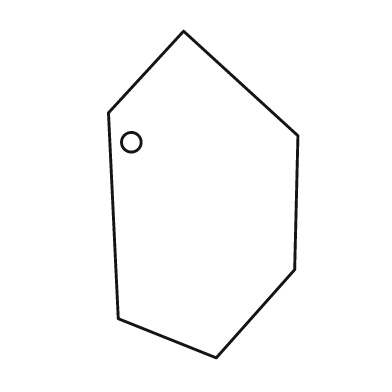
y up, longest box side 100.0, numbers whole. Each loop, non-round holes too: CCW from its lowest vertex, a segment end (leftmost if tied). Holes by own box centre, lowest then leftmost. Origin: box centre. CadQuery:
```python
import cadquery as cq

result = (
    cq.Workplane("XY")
    .moveTo(4.0, -50.0)
    .lineTo(28.0, -23.0)
    .lineTo(29.0, 18.0)
    .lineTo(-6.0, 50.0)
    .lineTo(-29.0, 25.0)
    .lineTo(-26.0, -38.0)
    .close()
    .moveTo(-22.0, 16.0)
    .circle(3.0)
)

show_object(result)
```